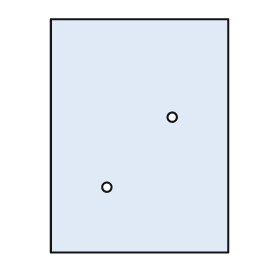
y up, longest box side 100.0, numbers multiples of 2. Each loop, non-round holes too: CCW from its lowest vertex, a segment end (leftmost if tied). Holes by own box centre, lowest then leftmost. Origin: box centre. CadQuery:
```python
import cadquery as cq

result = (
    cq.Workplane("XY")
    .moveTo(-38.0, -50.0)
    .lineTo(38.0, -50.0)
    .lineTo(38.0, 50.0)
    .lineTo(-38.0, 50.0)
    .close()
    .moveTo(-14.0, -22.0)
    .circle(2.0)
    .moveTo(14.0, 8.0)
    .circle(2.0)
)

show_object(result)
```